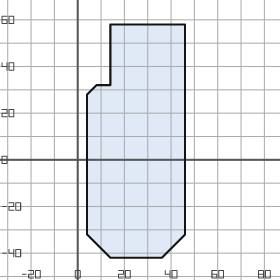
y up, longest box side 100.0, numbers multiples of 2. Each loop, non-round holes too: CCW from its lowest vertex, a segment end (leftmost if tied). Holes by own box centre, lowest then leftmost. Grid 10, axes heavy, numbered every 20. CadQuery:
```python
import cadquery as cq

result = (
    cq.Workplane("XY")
    .moveTo(14.0, -42.0)
    .lineTo(36.0, -42.0)
    .lineTo(46.0, -32.0)
    .lineTo(46.0, 58.0)
    .lineTo(14.0, 58.0)
    .lineTo(14.0, 32.0)
    .lineTo(8.0, 32.0)
    .lineTo(4.0, 28.0)
    .lineTo(4.0, -32.0)
    .close()
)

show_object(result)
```